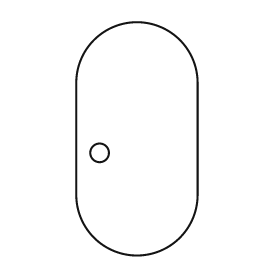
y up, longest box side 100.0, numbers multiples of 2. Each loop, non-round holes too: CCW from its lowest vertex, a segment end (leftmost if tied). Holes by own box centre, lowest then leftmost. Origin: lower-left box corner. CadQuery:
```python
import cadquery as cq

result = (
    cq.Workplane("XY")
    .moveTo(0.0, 26.0)
    .threePointArc((26.0, 0.0), (52.0, 26.0))
    .lineTo(52.0, 74.0)
    .threePointArc((26.0, 100.0), (0.0, 74.0))
    .close()
    .moveTo(10.0, 44.0)
    .circle(4.0)
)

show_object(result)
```